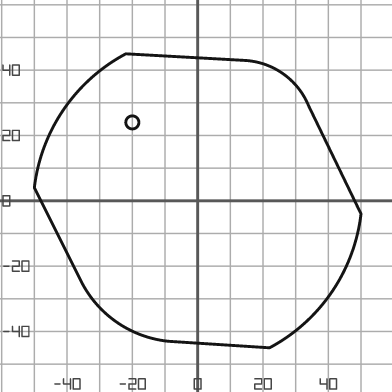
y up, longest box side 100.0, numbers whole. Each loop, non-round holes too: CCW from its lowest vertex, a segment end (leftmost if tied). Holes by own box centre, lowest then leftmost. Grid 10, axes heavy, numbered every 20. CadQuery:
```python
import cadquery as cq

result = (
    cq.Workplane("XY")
    .moveTo(22.0, -45.0)
    .threePointArc((41.0, -28.0), (50.0, -4.0))
    .lineTo(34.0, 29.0)
    .threePointArc((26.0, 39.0), (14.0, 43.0))
    .lineTo(-22.0, 45.0)
    .threePointArc((-41.0, 28.0), (-50.0, 4.0))
    .lineTo(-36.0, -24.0)
    .threePointArc((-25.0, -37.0), (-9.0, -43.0))
    .close()
    .moveTo(-20.0, 24.0)
    .circle(2.0)
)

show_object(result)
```